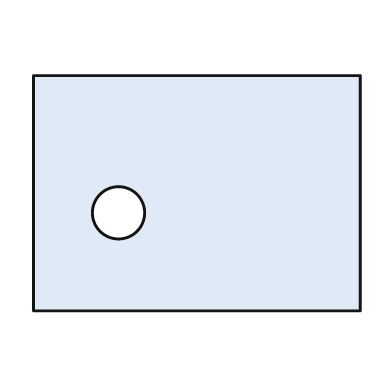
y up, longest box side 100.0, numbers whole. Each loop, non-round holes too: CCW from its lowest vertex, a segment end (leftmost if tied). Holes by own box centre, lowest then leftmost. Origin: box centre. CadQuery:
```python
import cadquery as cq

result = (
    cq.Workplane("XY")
    .moveTo(-50.0, -36.0)
    .lineTo(50.0, -36.0)
    .lineTo(50.0, 36.0)
    .lineTo(-50.0, 36.0)
    .close()
    .moveTo(-24.0, -6.0)
    .circle(8.0)
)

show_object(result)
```